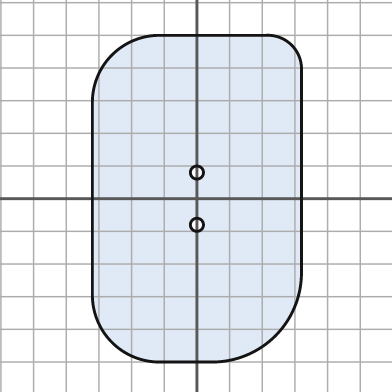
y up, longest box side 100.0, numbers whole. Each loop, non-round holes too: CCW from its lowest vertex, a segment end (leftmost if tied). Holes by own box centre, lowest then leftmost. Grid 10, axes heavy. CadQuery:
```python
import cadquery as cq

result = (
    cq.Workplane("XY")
    .moveTo(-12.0, -50.0)
    .lineTo(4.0, -50.0)
    .threePointArc((24.0, -42.0), (32.0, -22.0))
    .lineTo(32.0, 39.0)
    .threePointArc((29.0, 47.0), (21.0, 50.0))
    .lineTo(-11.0, 50.0)
    .threePointArc((-26.0, 44.0), (-32.0, 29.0))
    .lineTo(-32.0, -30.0)
    .threePointArc((-26.0, -44.0), (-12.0, -50.0))
    .close()
    .moveTo(0.0, -8.0)
    .circle(2.0)
    .moveTo(0.0, 8.0)
    .circle(2.0)
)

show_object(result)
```